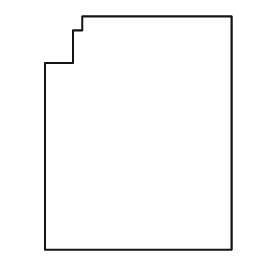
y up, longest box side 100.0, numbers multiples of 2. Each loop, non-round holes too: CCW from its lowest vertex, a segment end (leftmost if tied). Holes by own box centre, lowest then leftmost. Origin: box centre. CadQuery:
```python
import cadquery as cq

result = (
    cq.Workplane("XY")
    .moveTo(-40.0, -50.0)
    .lineTo(40.0, -50.0)
    .lineTo(40.0, 50.0)
    .lineTo(-24.0, 50.0)
    .lineTo(-24.0, 44.0)
    .lineTo(-28.0, 44.0)
    .lineTo(-28.0, 30.0)
    .lineTo(-40.0, 30.0)
    .close()
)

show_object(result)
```